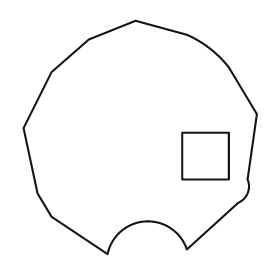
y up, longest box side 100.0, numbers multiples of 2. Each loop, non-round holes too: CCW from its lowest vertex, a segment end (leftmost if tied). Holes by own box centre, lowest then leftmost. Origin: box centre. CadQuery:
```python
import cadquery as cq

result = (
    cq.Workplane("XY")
    .moveTo(-14.0, -50.0)
    .threePointArc((2.0, -36.0), (20.0, -48.0))
    .lineTo(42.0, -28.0)
    .threePointArc((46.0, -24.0), (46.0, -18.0))
    .lineTo(50.0, 10.0)
    .lineTo(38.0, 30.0)
    .threePointArc((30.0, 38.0), (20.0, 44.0))
    .lineTo(-2.0, 50.0)
    .lineTo(-22.0, 42.0)
    .lineTo(-38.0, 28.0)
    .lineTo(-50.0, 4.0)
    .lineTo(-44.0, -24.0)
    .lineTo(-38.0, -34.0)
    .close()
    .moveTo(18.0, -18.0)
    .lineTo(38.0, -18.0)
    .lineTo(38.0, 2.0)
    .lineTo(18.0, 2.0)
    .close()
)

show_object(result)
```